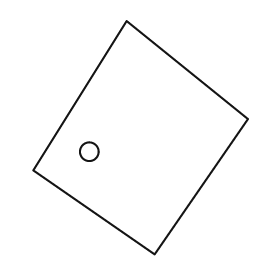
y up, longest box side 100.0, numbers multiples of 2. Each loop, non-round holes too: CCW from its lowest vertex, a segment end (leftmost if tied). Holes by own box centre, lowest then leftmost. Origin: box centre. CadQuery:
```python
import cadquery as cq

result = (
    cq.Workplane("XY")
    .moveTo(6.0, -50.0)
    .lineTo(46.0, 8.0)
    .lineTo(-6.0, 50.0)
    .lineTo(-46.0, -14.0)
    .close()
    .moveTo(-22.0, -6.0)
    .circle(4.0)
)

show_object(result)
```